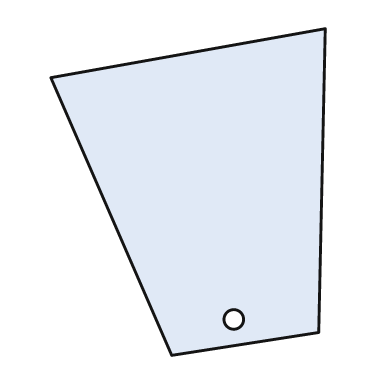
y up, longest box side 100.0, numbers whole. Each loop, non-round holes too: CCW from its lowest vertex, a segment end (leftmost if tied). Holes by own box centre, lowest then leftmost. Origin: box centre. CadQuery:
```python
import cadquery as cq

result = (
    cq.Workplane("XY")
    .moveTo(-5.0, -50.0)
    .lineTo(40.0, -43.0)
    .lineTo(42.0, 50.0)
    .lineTo(-42.0, 35.0)
    .close()
    .moveTo(14.0, -39.0)
    .circle(3.0)
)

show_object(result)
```